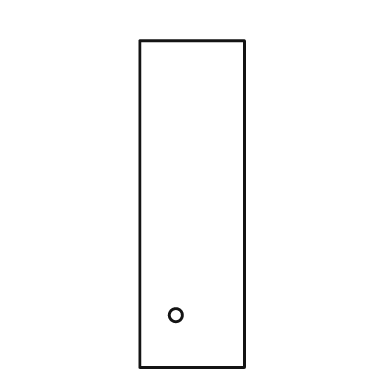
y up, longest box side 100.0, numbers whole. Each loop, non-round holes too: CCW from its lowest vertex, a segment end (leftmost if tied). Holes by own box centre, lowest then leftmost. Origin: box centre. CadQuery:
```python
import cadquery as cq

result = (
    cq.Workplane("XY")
    .moveTo(-16.0, -50.0)
    .lineTo(16.0, -50.0)
    .lineTo(16.0, 50.0)
    .lineTo(-16.0, 50.0)
    .close()
    .moveTo(-5.0, -34.0)
    .circle(2.0)
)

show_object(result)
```